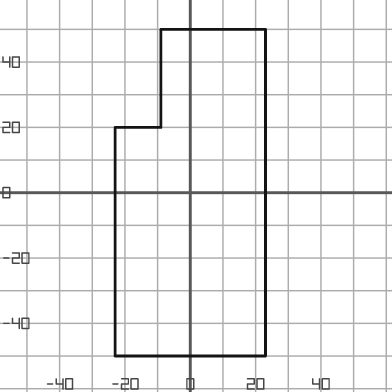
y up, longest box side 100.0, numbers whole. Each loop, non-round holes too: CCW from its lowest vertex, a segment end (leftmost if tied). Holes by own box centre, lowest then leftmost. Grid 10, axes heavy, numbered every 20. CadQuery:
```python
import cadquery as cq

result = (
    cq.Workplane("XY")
    .moveTo(-23.0, -50.0)
    .lineTo(23.0, -50.0)
    .lineTo(23.0, 50.0)
    .lineTo(-9.0, 50.0)
    .lineTo(-9.0, 20.0)
    .lineTo(-23.0, 20.0)
    .close()
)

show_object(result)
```